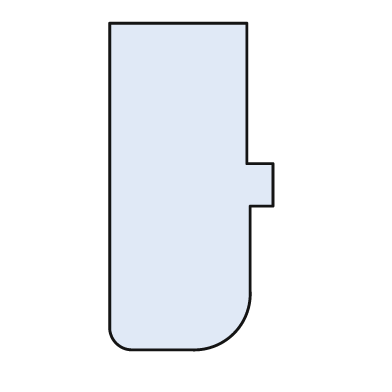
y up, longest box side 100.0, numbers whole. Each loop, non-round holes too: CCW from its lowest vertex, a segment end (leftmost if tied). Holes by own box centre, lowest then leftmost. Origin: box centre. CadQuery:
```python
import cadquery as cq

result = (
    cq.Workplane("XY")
    .moveTo(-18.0, -50.0)
    .lineTo(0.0, -50.0)
    .threePointArc((13.0, -45.0), (18.0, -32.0))
    .lineTo(18.0, -6.0)
    .lineTo(25.0, -6.0)
    .lineTo(25.0, 7.0)
    .lineTo(17.0, 7.0)
    .lineTo(17.0, 50.0)
    .lineTo(-25.0, 50.0)
    .lineTo(-25.0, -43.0)
    .threePointArc((-23.0, -48.0), (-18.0, -50.0))
    .close()
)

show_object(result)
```